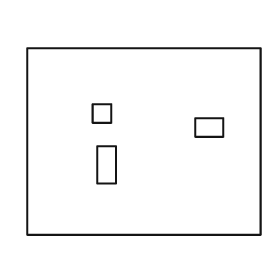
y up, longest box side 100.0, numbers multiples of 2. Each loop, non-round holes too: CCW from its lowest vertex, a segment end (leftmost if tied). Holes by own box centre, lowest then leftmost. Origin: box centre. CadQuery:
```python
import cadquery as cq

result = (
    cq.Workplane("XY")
    .moveTo(-50.0, -40.0)
    .lineTo(50.0, -40.0)
    .lineTo(50.0, 40.0)
    .lineTo(-50.0, 40.0)
    .close()
    .moveTo(-20.0, -18.0)
    .lineTo(-12.0, -18.0)
    .lineTo(-12.0, -2.0)
    .lineTo(-20.0, -2.0)
    .close()
    .moveTo(22.0, 2.0)
    .lineTo(34.0, 2.0)
    .lineTo(34.0, 10.0)
    .lineTo(22.0, 10.0)
    .close()
    .moveTo(-22.0, 8.0)
    .lineTo(-14.0, 8.0)
    .lineTo(-14.0, 16.0)
    .lineTo(-22.0, 16.0)
    .close()
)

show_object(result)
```